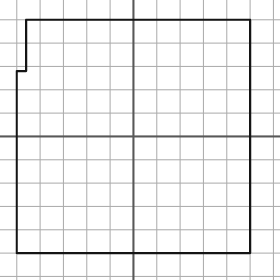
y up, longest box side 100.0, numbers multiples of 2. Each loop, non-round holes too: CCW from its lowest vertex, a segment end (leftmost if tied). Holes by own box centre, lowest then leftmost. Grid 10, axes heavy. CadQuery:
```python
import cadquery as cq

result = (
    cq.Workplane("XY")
    .moveTo(-50.0, -50.0)
    .lineTo(50.0, -50.0)
    .lineTo(50.0, 50.0)
    .lineTo(-46.0, 50.0)
    .lineTo(-46.0, 28.0)
    .lineTo(-50.0, 28.0)
    .close()
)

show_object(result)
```